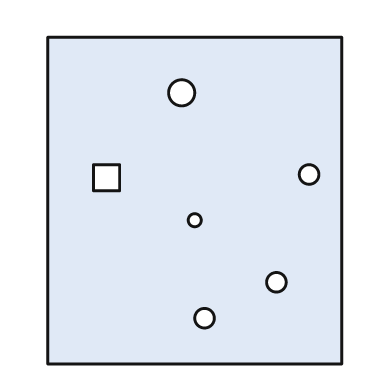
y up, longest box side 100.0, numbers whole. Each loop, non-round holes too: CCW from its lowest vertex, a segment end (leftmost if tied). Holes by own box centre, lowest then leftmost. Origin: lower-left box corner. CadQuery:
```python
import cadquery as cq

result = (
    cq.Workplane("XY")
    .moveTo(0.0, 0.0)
    .lineTo(90.0, 0.0)
    .lineTo(90.0, 100.0)
    .lineTo(0.0, 100.0)
    .close()
    .moveTo(48.0, 14.0)
    .circle(3.0)
    .moveTo(70.0, 25.0)
    .circle(3.0)
    .moveTo(45.0, 44.0)
    .circle(2.0)
    .moveTo(14.0, 53.0)
    .lineTo(22.0, 53.0)
    .lineTo(22.0, 61.0)
    .lineTo(14.0, 61.0)
    .close()
    .moveTo(80.0, 58.0)
    .circle(3.0)
    .moveTo(41.0, 83.0)
    .circle(4.0)
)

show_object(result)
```